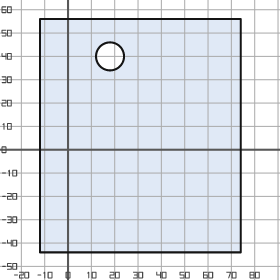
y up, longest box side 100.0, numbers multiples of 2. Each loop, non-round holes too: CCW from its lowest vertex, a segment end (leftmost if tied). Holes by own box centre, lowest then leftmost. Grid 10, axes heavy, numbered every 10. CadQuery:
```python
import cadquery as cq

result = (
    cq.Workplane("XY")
    .moveTo(-12.0, -44.0)
    .lineTo(74.0, -44.0)
    .lineTo(74.0, 56.0)
    .lineTo(-12.0, 56.0)
    .close()
    .moveTo(18.0, 40.0)
    .circle(6.0)
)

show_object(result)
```